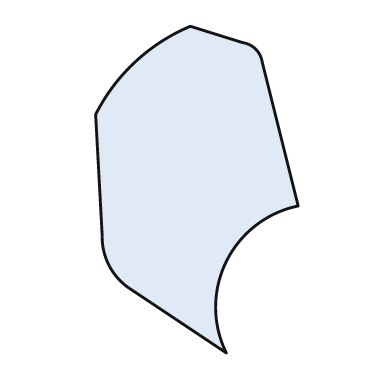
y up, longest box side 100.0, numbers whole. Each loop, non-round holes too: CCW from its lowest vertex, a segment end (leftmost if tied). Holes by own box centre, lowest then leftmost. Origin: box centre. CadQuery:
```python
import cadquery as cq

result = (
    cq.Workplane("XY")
    .moveTo(9.0, -50.0)
    .threePointArc((9.0, -22.0), (31.0, -5.0))
    .lineTo(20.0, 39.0)
    .threePointArc((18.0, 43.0), (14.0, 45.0))
    .lineTo(-2.0, 50.0)
    .threePointArc((-19.0, 39.0), (-31.0, 23.0))
    .lineTo(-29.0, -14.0)
    .threePointArc((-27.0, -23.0), (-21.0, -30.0))
    .close()
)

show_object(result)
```